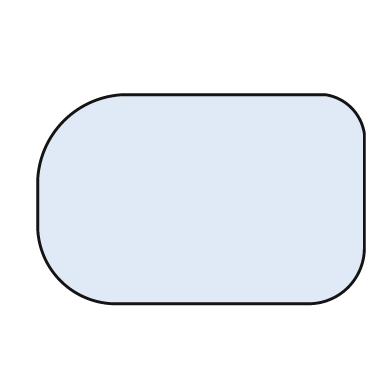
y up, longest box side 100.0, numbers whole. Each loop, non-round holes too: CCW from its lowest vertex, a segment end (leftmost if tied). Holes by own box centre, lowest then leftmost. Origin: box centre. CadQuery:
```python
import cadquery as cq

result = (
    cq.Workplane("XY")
    .moveTo(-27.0, -32.0)
    .lineTo(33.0, -32.0)
    .threePointArc((45.0, -27.0), (50.0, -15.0))
    .lineTo(50.0, 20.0)
    .threePointArc((46.0, 28.0), (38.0, 32.0))
    .lineTo(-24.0, 32.0)
    .threePointArc((-42.0, 24.0), (-50.0, 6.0))
    .lineTo(-50.0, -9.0)
    .threePointArc((-43.0, -25.0), (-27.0, -32.0))
    .close()
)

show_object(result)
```